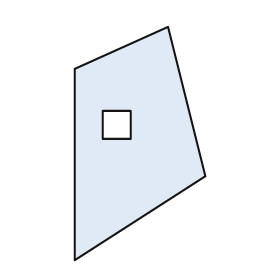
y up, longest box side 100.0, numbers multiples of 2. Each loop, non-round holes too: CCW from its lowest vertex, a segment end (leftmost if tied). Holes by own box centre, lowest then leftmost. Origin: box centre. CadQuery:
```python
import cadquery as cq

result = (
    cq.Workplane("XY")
    .moveTo(-28.0, -50.0)
    .lineTo(28.0, -14.0)
    .lineTo(12.0, 50.0)
    .lineTo(-28.0, 32.0)
    .close()
    .moveTo(-16.0, 2.0)
    .lineTo(-4.0, 2.0)
    .lineTo(-4.0, 14.0)
    .lineTo(-16.0, 14.0)
    .close()
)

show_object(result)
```